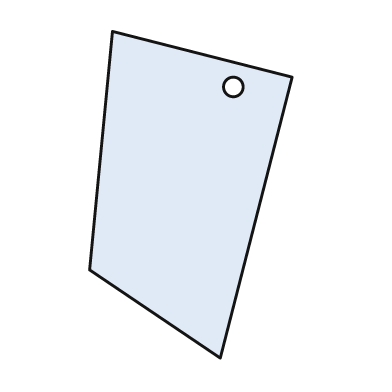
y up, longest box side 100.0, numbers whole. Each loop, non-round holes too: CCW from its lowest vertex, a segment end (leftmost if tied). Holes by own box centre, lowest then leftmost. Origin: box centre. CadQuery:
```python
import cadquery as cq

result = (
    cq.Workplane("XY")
    .moveTo(9.0, -50.0)
    .lineTo(31.0, 36.0)
    .lineTo(-24.0, 50.0)
    .lineTo(-31.0, -23.0)
    .close()
    .moveTo(13.0, 33.0)
    .circle(3.0)
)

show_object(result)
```